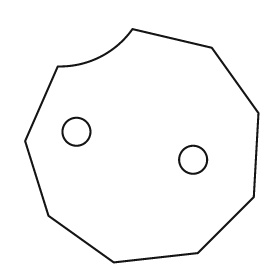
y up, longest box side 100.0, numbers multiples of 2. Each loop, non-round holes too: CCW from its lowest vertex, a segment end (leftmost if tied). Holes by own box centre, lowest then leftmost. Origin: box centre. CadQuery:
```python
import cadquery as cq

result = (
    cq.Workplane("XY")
    .moveTo(-12.0, -50.0)
    .lineTo(24.0, -46.0)
    .lineTo(48.0, -22.0)
    .lineTo(50.0, 14.0)
    .lineTo(30.0, 42.0)
    .lineTo(-4.0, 50.0)
    .threePointArc((-18.0, 38.0), (-36.0, 34.0))
    .lineTo(-50.0, 2.0)
    .lineTo(-40.0, -30.0)
    .close()
    .moveTo(22.0, -6.0)
    .circle(6.0)
    .moveTo(-28.0, 6.0)
    .circle(6.0)
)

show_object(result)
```